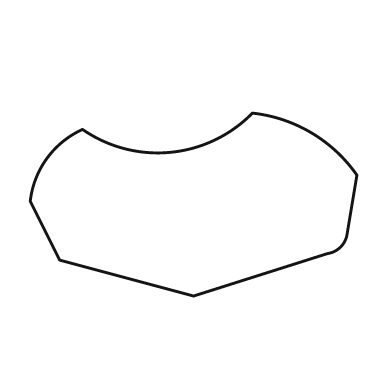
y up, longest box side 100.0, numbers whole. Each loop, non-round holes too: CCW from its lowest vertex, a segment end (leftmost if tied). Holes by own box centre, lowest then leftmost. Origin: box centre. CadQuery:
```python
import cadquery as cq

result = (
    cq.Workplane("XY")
    .moveTo(0.0, -28.0)
    .lineTo(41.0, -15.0)
    .threePointArc((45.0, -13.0), (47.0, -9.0))
    .lineTo(50.0, 9.0)
    .threePointArc((36.0, 22.0), (18.0, 28.0))
    .threePointArc((-7.0, 16.0), (-34.0, 23.0))
    .threePointArc((-45.0, 14.0), (-50.0, 1.0))
    .lineTo(-41.0, -17.0)
    .close()
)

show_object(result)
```